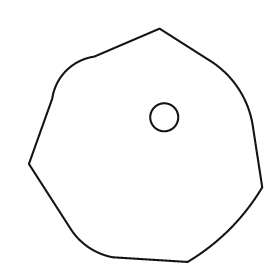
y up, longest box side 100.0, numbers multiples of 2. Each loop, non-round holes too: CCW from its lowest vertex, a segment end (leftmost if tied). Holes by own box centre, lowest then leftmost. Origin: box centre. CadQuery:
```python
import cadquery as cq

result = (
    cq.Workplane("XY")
    .moveTo(18.0, -50.0)
    .threePointArc((36.0, -36.0), (50.0, -18.0))
    .lineTo(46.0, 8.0)
    .threePointArc((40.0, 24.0), (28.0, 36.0))
    .lineTo(6.0, 50.0)
    .lineTo(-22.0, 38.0)
    .threePointArc((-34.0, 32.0), (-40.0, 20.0))
    .lineTo(-50.0, -8.0)
    .lineTo(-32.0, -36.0)
    .threePointArc((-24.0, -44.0), (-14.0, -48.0))
    .close()
    .moveTo(8.0, 12.0)
    .circle(6.0)
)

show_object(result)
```